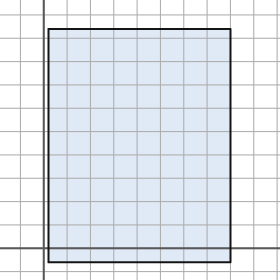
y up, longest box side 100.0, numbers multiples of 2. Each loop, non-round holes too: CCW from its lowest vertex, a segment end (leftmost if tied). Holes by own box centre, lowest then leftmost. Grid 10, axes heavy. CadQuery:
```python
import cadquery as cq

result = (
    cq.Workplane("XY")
    .moveTo(2.0, -6.0)
    .lineTo(80.0, -6.0)
    .lineTo(80.0, 94.0)
    .lineTo(2.0, 94.0)
    .close()
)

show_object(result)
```